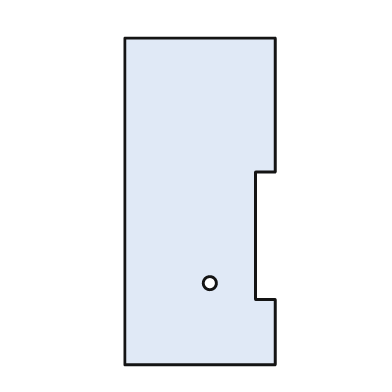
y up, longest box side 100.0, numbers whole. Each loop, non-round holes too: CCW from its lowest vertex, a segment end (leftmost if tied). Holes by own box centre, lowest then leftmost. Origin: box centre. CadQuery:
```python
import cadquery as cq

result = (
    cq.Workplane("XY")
    .moveTo(-23.0, -50.0)
    .lineTo(23.0, -50.0)
    .lineTo(23.0, -30.0)
    .lineTo(17.0, -30.0)
    .lineTo(17.0, 9.0)
    .lineTo(23.0, 9.0)
    .lineTo(23.0, 50.0)
    .lineTo(-23.0, 50.0)
    .close()
    .moveTo(3.0, -25.0)
    .circle(2.0)
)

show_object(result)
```